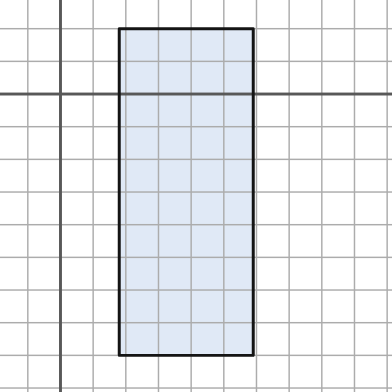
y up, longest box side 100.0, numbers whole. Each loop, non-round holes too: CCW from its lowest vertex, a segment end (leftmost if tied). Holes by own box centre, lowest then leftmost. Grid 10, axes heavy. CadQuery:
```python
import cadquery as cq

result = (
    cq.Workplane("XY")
    .moveTo(18.0, -80.0)
    .lineTo(59.0, -80.0)
    .lineTo(59.0, 20.0)
    .lineTo(18.0, 20.0)
    .close()
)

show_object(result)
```